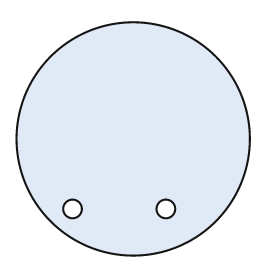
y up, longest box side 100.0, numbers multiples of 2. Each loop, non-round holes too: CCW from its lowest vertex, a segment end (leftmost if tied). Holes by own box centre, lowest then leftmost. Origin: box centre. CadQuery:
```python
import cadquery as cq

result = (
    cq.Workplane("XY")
    .moveTo(0.0, 0.0)
    .circle(50.0)
    .moveTo(-26.0, -30.0)
    .circle(4.0)
    .moveTo(14.0, -30.0)
    .circle(4.0)
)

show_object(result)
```